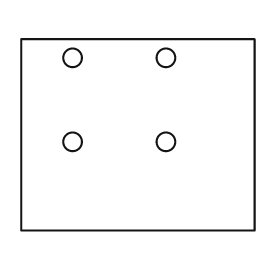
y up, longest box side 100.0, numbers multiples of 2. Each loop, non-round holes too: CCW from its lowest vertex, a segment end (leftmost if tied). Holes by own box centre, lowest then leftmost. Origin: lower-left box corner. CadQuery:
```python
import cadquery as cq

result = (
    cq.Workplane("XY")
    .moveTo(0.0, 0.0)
    .lineTo(100.0, 0.0)
    .lineTo(100.0, 82.0)
    .lineTo(0.0, 82.0)
    .close()
    .moveTo(22.0, 38.0)
    .circle(4.0)
    .moveTo(62.0, 38.0)
    .circle(4.0)
    .moveTo(22.0, 74.0)
    .circle(4.0)
    .moveTo(62.0, 74.0)
    .circle(4.0)
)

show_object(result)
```